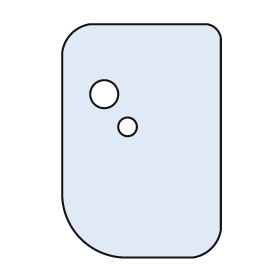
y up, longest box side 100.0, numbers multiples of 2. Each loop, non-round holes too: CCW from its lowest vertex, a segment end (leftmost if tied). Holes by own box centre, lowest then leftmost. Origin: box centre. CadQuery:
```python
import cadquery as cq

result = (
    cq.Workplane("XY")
    .moveTo(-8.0, -50.0)
    .lineTo(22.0, -50.0)
    .threePointArc((30.0, -46.0), (34.0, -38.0))
    .lineTo(34.0, 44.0)
    .threePointArc((32.0, 48.0), (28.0, 50.0))
    .lineTo(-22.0, 50.0)
    .threePointArc((-30.0, 46.0), (-34.0, 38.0))
    .lineTo(-34.0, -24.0)
    .threePointArc((-26.0, -42.0), (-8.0, -50.0))
    .close()
    .moveTo(-6.0, 6.0)
    .circle(4.0)
    .moveTo(-16.0, 20.0)
    .circle(6.0)
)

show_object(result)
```